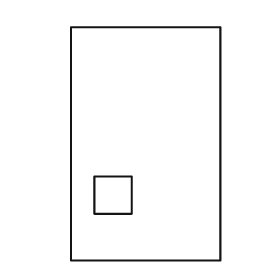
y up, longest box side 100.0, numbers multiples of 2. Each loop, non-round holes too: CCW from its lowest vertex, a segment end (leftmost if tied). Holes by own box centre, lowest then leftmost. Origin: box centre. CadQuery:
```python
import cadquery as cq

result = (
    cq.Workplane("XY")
    .moveTo(-32.0, -50.0)
    .lineTo(32.0, -50.0)
    .lineTo(32.0, 50.0)
    .lineTo(-32.0, 50.0)
    .close()
    .moveTo(-22.0, -30.0)
    .lineTo(-6.0, -30.0)
    .lineTo(-6.0, -14.0)
    .lineTo(-22.0, -14.0)
    .close()
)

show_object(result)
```